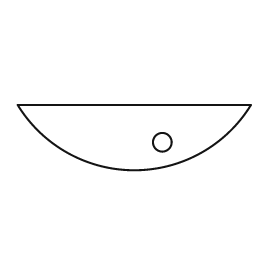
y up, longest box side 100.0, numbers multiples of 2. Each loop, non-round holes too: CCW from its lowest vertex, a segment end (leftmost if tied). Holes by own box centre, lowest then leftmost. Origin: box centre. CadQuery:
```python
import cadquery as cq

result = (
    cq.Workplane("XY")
    .moveTo(-50.0, 14.0)
    .threePointArc((0.0, -14.0), (50.0, 14.0))
    .close()
    .moveTo(12.0, -2.0)
    .circle(4.0)
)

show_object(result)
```